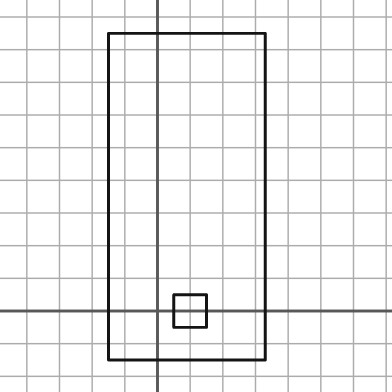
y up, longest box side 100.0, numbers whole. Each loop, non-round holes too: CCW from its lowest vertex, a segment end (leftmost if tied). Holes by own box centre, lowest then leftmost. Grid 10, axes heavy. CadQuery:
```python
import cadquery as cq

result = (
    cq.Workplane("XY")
    .moveTo(-15.0, -15.0)
    .lineTo(33.0, -15.0)
    .lineTo(33.0, 85.0)
    .lineTo(-15.0, 85.0)
    .close()
    .moveTo(5.0, -5.0)
    .lineTo(15.0, -5.0)
    .lineTo(15.0, 5.0)
    .lineTo(5.0, 5.0)
    .close()
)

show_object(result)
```